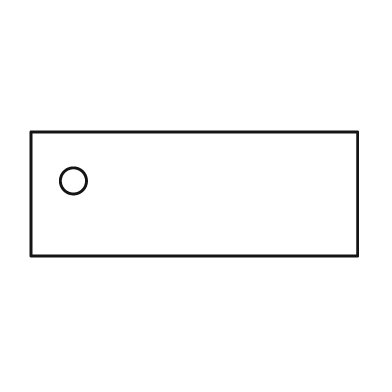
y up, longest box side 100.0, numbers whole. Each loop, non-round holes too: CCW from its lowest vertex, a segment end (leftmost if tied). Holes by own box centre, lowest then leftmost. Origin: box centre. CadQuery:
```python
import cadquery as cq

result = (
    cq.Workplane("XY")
    .moveTo(-50.0, -19.0)
    .lineTo(50.0, -19.0)
    .lineTo(50.0, 19.0)
    .lineTo(-50.0, 19.0)
    .close()
    .moveTo(-37.0, 4.0)
    .circle(4.0)
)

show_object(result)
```